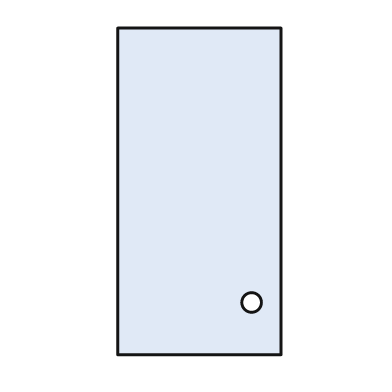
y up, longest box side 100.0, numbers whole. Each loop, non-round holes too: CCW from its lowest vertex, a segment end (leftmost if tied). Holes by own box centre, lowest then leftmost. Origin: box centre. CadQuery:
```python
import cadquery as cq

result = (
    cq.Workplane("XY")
    .moveTo(-25.0, -50.0)
    .lineTo(25.0, -50.0)
    .lineTo(25.0, 50.0)
    .lineTo(-25.0, 50.0)
    .close()
    .moveTo(16.0, -34.0)
    .circle(3.0)
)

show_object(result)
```